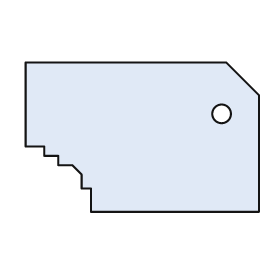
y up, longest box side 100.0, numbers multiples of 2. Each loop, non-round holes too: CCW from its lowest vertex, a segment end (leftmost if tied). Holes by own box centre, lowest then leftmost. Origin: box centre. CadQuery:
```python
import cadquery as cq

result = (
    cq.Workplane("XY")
    .moveTo(-22.0, -32.0)
    .lineTo(50.0, -32.0)
    .lineTo(50.0, 18.0)
    .lineTo(36.0, 32.0)
    .lineTo(-50.0, 32.0)
    .lineTo(-50.0, -4.0)
    .lineTo(-42.0, -4.0)
    .lineTo(-42.0, -8.0)
    .lineTo(-36.0, -8.0)
    .lineTo(-36.0, -12.0)
    .lineTo(-30.0, -12.0)
    .lineTo(-26.0, -16.0)
    .lineTo(-26.0, -22.0)
    .lineTo(-22.0, -22.0)
    .close()
    .moveTo(34.0, 10.0)
    .circle(4.0)
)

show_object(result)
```